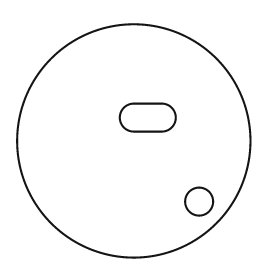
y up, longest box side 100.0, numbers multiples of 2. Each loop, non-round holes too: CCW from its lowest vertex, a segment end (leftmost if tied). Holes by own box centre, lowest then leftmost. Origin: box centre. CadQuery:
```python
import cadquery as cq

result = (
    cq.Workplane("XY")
    .moveTo(0.0, 0.0)
    .circle(50.0)
    .moveTo(28.0, -26.0)
    .circle(6.0)
    .moveTo(0.0, 4.0)
    .lineTo(12.0, 4.0)
    .threePointArc((18.0, 10.0), (12.0, 16.0))
    .lineTo(0.0, 16.0)
    .threePointArc((-6.0, 10.0), (0.0, 4.0))
    .close()
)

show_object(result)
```